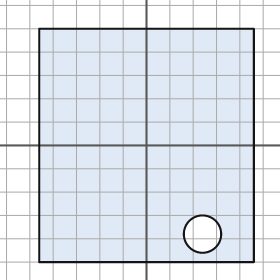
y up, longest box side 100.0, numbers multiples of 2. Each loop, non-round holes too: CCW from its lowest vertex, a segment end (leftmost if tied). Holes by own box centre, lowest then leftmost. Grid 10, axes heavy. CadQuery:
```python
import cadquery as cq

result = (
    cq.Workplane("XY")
    .moveTo(-46.0, -50.0)
    .lineTo(46.0, -50.0)
    .lineTo(46.0, 50.0)
    .lineTo(-46.0, 50.0)
    .close()
    .moveTo(24.0, -38.0)
    .circle(8.0)
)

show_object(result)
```